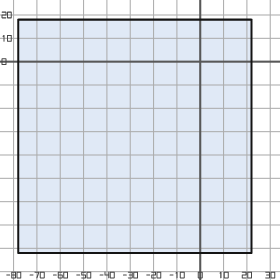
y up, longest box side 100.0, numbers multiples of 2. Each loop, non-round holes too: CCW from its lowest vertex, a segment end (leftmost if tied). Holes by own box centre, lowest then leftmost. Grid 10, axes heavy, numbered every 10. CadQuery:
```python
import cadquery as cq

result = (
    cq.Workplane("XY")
    .moveTo(-78.0, -82.0)
    .lineTo(22.0, -82.0)
    .lineTo(22.0, 18.0)
    .lineTo(-78.0, 18.0)
    .close()
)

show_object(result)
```